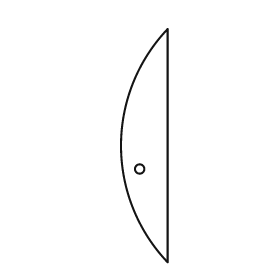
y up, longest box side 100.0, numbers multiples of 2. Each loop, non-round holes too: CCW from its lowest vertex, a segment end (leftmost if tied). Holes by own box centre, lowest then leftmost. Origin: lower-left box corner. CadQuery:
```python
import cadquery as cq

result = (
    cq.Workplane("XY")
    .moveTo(20.0, 0.0)
    .lineTo(20.0, 100.0)
    .threePointArc((0.0, 50.0), (20.0, 0.0))
    .close()
    .moveTo(8.0, 40.0)
    .circle(2.0)
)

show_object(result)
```